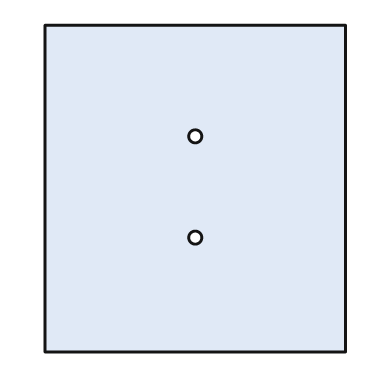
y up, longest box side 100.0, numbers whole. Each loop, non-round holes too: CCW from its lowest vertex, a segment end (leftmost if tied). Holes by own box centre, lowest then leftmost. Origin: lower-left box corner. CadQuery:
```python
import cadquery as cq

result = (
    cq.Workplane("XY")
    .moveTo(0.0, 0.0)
    .lineTo(92.0, 0.0)
    .lineTo(92.0, 100.0)
    .lineTo(0.0, 100.0)
    .close()
    .moveTo(46.0, 35.0)
    .circle(2.0)
    .moveTo(46.0, 66.0)
    .circle(2.0)
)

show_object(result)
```